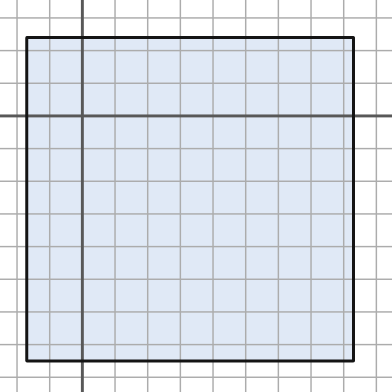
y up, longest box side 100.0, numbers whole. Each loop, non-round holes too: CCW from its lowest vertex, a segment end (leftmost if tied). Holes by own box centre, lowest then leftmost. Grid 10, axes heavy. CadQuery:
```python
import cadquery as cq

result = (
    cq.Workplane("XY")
    .moveTo(-17.0, -75.0)
    .lineTo(83.0, -75.0)
    .lineTo(83.0, 24.0)
    .lineTo(-17.0, 24.0)
    .close()
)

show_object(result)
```